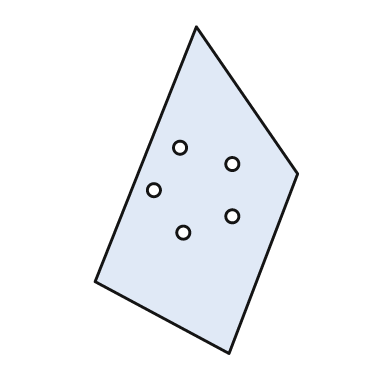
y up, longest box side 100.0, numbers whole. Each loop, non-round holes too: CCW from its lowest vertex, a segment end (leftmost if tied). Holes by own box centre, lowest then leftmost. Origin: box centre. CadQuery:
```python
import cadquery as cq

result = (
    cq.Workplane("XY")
    .moveTo(10.0, -50.0)
    .lineTo(31.0, 5.0)
    .lineTo(0.0, 50.0)
    .lineTo(-31.0, -28.0)
    .close()
    .moveTo(-4.0, -13.0)
    .circle(2.0)
    .moveTo(11.0, -8.0)
    .circle(2.0)
    .moveTo(-13.0, 0.0)
    .circle(2.0)
    .moveTo(11.0, 8.0)
    .circle(2.0)
    .moveTo(-5.0, 13.0)
    .circle(2.0)
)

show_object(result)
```